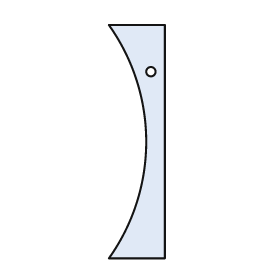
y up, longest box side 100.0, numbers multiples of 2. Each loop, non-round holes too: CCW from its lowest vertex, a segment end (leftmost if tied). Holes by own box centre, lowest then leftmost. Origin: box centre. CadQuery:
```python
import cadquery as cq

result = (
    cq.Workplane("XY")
    .moveTo(-12.0, -50.0)
    .lineTo(12.0, -50.0)
    .lineTo(12.0, 50.0)
    .lineTo(-12.0, 50.0)
    .threePointArc((4.0, 0.0), (-12.0, -50.0))
    .close()
    .moveTo(6.0, 30.0)
    .circle(2.0)
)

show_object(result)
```